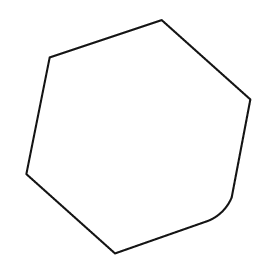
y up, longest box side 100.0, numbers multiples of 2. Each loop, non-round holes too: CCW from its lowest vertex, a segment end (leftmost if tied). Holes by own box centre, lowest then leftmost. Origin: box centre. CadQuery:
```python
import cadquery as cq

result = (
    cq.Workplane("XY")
    .moveTo(-10.0, -50.0)
    .lineTo(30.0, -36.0)
    .threePointArc((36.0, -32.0), (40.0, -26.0))
    .lineTo(48.0, 16.0)
    .lineTo(10.0, 50.0)
    .lineTo(-38.0, 34.0)
    .lineTo(-48.0, -16.0)
    .close()
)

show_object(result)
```